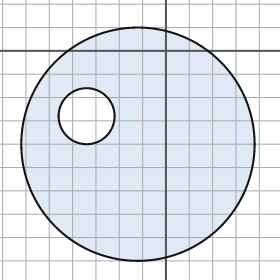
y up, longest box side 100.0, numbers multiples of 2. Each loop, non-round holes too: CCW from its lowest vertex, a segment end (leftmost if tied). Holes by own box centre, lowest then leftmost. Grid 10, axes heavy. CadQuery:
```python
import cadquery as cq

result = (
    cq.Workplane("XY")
    .moveTo(-12.0, -40.0)
    .circle(50.0)
    .moveTo(-34.0, -28.0)
    .circle(12.0)
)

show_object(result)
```